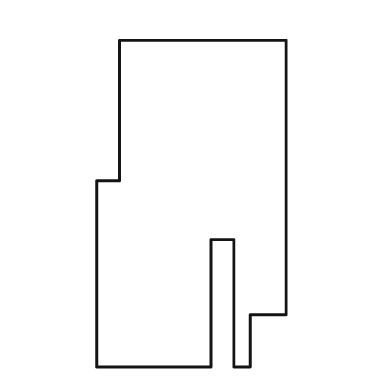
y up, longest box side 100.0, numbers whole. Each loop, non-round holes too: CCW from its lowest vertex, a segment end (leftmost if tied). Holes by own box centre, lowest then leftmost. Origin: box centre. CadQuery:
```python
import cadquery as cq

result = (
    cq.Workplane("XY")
    .moveTo(-29.0, -50.0)
    .lineTo(6.0, -50.0)
    .lineTo(6.0, -11.0)
    .lineTo(13.0, -11.0)
    .lineTo(13.0, -50.0)
    .lineTo(18.0, -50.0)
    .lineTo(18.0, -34.0)
    .lineTo(29.0, -34.0)
    .lineTo(29.0, 50.0)
    .lineTo(-22.0, 50.0)
    .lineTo(-22.0, 7.0)
    .lineTo(-29.0, 7.0)
    .close()
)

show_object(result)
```